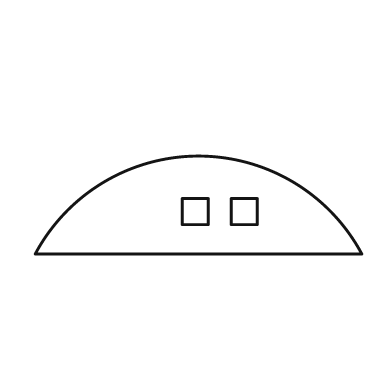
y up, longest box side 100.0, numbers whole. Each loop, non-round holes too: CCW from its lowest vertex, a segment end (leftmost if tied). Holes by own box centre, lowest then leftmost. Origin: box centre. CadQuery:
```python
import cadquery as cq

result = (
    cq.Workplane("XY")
    .moveTo(-50.0, -15.0)
    .lineTo(50.0, -15.0)
    .threePointArc((0.0, 15.0), (-50.0, -15.0))
    .close()
    .moveTo(-5.0, -6.0)
    .lineTo(3.0, -6.0)
    .lineTo(3.0, 2.0)
    .lineTo(-5.0, 2.0)
    .close()
    .moveTo(10.0, -6.0)
    .lineTo(18.0, -6.0)
    .lineTo(18.0, 2.0)
    .lineTo(10.0, 2.0)
    .close()
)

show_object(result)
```